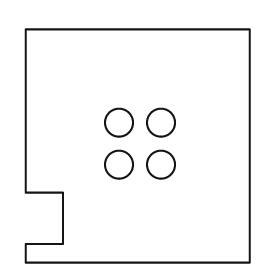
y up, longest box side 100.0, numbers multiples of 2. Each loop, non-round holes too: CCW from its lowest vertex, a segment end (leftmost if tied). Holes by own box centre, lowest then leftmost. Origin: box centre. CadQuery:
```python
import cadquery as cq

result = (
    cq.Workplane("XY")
    .moveTo(-48.0, -50.0)
    .lineTo(48.0, -50.0)
    .lineTo(48.0, 50.0)
    .lineTo(-48.0, 50.0)
    .lineTo(-48.0, -20.0)
    .lineTo(-32.0, -20.0)
    .lineTo(-32.0, -42.0)
    .lineTo(-48.0, -42.0)
    .close()
    .moveTo(-8.0, -8.0)
    .circle(6.0)
    .moveTo(10.0, -8.0)
    .circle(6.0)
    .moveTo(-8.0, 10.0)
    .circle(6.0)
    .moveTo(10.0, 10.0)
    .circle(6.0)
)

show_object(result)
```